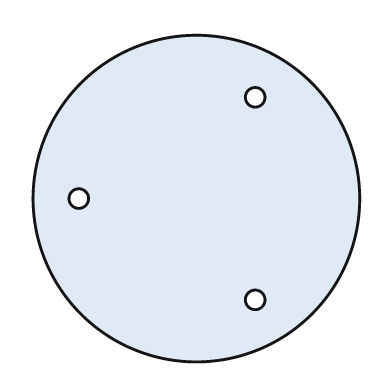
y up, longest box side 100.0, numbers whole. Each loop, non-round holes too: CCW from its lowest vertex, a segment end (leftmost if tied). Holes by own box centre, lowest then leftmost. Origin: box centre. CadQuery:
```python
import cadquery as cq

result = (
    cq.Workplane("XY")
    .moveTo(0.0, 0.0)
    .circle(50.0)
    .moveTo(18.0, -31.0)
    .circle(3.0)
    .moveTo(-36.0, 0.0)
    .circle(3.0)
    .moveTo(18.0, 31.0)
    .circle(3.0)
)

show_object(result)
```